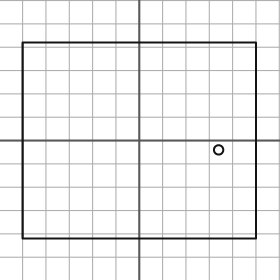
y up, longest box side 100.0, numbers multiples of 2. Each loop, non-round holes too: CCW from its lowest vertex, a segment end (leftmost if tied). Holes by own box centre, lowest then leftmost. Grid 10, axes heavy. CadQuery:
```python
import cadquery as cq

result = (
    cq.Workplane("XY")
    .moveTo(-50.0, -42.0)
    .lineTo(50.0, -42.0)
    .lineTo(50.0, 42.0)
    .lineTo(-50.0, 42.0)
    .close()
    .moveTo(34.0, -4.0)
    .circle(2.0)
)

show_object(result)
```